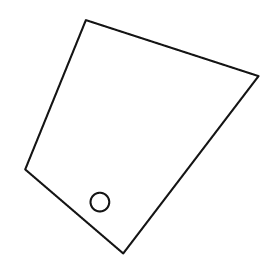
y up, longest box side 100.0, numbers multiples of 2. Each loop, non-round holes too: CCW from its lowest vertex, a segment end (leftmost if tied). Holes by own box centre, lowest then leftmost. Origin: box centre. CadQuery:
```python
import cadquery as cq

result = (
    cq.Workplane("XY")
    .moveTo(-8.0, -50.0)
    .lineTo(50.0, 26.0)
    .lineTo(-24.0, 50.0)
    .lineTo(-50.0, -14.0)
    .close()
    .moveTo(-18.0, -28.0)
    .circle(4.0)
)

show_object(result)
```